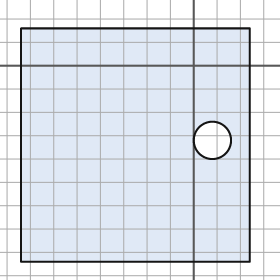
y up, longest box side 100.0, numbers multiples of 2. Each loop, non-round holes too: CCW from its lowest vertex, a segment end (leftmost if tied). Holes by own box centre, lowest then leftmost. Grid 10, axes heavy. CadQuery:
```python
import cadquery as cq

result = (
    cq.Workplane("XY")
    .moveTo(-74.0, -84.0)
    .lineTo(24.0, -84.0)
    .lineTo(24.0, 16.0)
    .lineTo(-74.0, 16.0)
    .close()
    .moveTo(8.0, -32.0)
    .circle(8.0)
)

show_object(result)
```